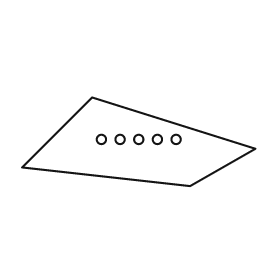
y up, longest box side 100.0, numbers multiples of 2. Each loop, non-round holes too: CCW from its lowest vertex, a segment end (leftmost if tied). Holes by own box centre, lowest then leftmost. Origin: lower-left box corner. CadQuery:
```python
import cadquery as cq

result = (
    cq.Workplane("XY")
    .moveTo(72.0, 0.0)
    .lineTo(100.0, 16.0)
    .lineTo(30.0, 38.0)
    .lineTo(0.0, 8.0)
    .close()
    .moveTo(34.0, 20.0)
    .circle(2.0)
    .moveTo(42.0, 20.0)
    .circle(2.0)
    .moveTo(50.0, 20.0)
    .circle(2.0)
    .moveTo(58.0, 20.0)
    .circle(2.0)
    .moveTo(66.0, 20.0)
    .circle(2.0)
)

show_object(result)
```